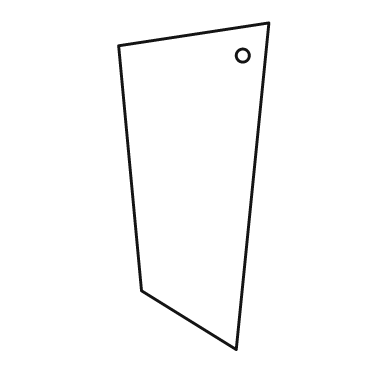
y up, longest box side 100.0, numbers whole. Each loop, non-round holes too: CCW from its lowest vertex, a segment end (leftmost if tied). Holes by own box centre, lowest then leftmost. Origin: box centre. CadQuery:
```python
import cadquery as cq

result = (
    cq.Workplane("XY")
    .moveTo(13.0, -50.0)
    .lineTo(23.0, 50.0)
    .lineTo(-23.0, 43.0)
    .lineTo(-16.0, -32.0)
    .close()
    .moveTo(15.0, 40.0)
    .circle(2.0)
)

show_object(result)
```